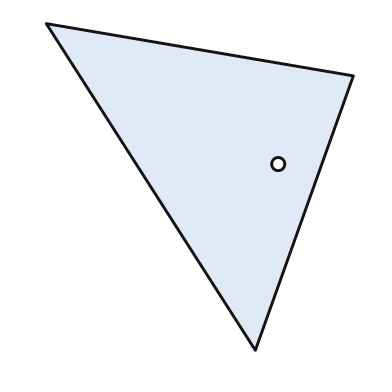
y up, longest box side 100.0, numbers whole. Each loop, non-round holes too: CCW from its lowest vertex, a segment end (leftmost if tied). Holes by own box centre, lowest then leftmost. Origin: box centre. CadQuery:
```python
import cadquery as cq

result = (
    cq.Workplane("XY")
    .moveTo(17.0, -50.0)
    .lineTo(47.0, 34.0)
    .lineTo(-47.0, 50.0)
    .close()
    .moveTo(24.0, 7.0)
    .circle(2.0)
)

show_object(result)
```